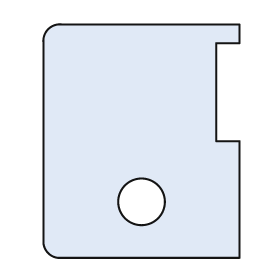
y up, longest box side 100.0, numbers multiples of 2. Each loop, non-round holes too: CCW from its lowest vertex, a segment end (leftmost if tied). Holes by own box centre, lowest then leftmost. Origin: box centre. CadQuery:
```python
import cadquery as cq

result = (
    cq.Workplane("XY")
    .moveTo(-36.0, -50.0)
    .lineTo(42.0, -50.0)
    .lineTo(42.0, 0.0)
    .lineTo(32.0, 0.0)
    .lineTo(32.0, 42.0)
    .lineTo(42.0, 42.0)
    .lineTo(42.0, 50.0)
    .lineTo(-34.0, 50.0)
    .threePointArc((-40.0, 48.0), (-42.0, 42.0))
    .lineTo(-42.0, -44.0)
    .threePointArc((-40.0, -48.0), (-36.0, -50.0))
    .close()
    .moveTo(0.0, -26.0)
    .circle(10.0)
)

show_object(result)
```